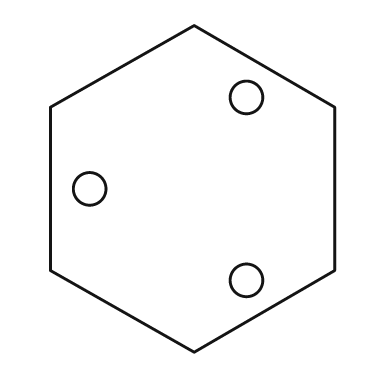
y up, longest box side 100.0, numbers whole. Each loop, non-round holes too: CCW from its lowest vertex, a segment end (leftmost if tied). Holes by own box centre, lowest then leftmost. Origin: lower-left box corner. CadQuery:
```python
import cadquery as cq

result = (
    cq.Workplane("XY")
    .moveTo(44.0, 0.0)
    .lineTo(87.0, 25.0)
    .lineTo(87.0, 75.0)
    .lineTo(44.0, 100.0)
    .lineTo(0.0, 75.0)
    .lineTo(0.0, 25.0)
    .close()
    .moveTo(60.0, 22.0)
    .circle(5.0)
    .moveTo(12.0, 50.0)
    .circle(5.0)
    .moveTo(60.0, 78.0)
    .circle(5.0)
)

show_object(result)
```